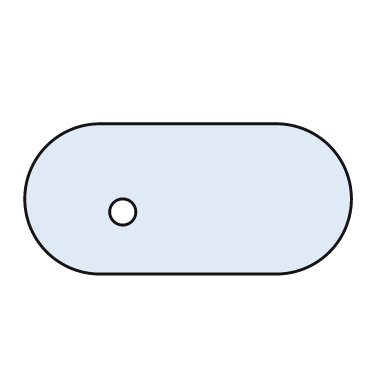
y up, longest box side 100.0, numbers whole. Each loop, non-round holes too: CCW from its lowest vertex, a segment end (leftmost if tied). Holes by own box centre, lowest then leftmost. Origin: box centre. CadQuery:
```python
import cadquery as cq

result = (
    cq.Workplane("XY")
    .moveTo(-27.0, -23.0)
    .lineTo(27.0, -23.0)
    .threePointArc((50.0, 0.0), (27.0, 23.0))
    .lineTo(-27.0, 23.0)
    .threePointArc((-50.0, 0.0), (-27.0, -23.0))
    .close()
    .moveTo(-20.0, -4.0)
    .circle(4.0)
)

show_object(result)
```